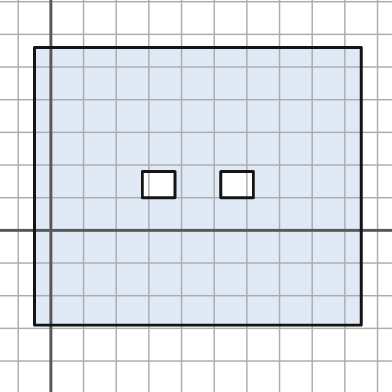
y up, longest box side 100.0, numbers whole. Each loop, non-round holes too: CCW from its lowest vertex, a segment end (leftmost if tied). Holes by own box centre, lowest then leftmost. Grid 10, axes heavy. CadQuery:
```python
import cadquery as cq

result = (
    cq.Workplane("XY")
    .moveTo(-5.0, -29.0)
    .lineTo(95.0, -29.0)
    .lineTo(95.0, 56.0)
    .lineTo(-5.0, 56.0)
    .close()
    .moveTo(28.0, 10.0)
    .lineTo(38.0, 10.0)
    .lineTo(38.0, 18.0)
    .lineTo(28.0, 18.0)
    .close()
    .moveTo(52.0, 10.0)
    .lineTo(62.0, 10.0)
    .lineTo(62.0, 18.0)
    .lineTo(52.0, 18.0)
    .close()
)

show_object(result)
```